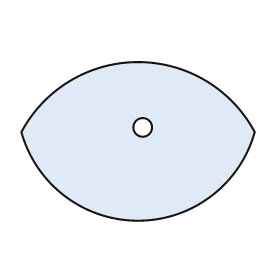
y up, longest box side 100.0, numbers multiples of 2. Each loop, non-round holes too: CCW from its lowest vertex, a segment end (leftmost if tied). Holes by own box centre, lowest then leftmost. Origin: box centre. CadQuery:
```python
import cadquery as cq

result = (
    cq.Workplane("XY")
    .moveTo(-50.0, 4.0)
    .threePointArc((0.0, -34.0), (50.0, 4.0))
    .threePointArc((0.0, 34.0), (-50.0, 4.0))
    .close()
    .moveTo(2.0, 6.0)
    .circle(4.0)
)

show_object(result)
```